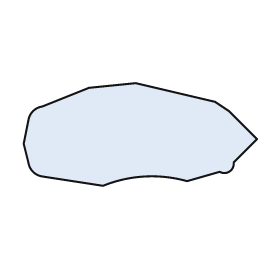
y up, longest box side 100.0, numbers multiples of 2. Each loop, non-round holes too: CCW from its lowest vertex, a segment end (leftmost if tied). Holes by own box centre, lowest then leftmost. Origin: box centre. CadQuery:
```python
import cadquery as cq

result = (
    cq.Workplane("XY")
    .moveTo(-16.0, -22.0)
    .threePointArc((2.0, -18.0), (20.0, -20.0))
    .lineTo(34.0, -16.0)
    .threePointArc((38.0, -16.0), (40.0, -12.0))
    .lineTo(50.0, -2.0)
    .lineTo(38.0, 10.0)
    .lineTo(32.0, 14.0)
    .lineTo(-2.0, 22.0)
    .lineTo(-22.0, 20.0)
    .lineTo(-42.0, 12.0)
    .threePointArc((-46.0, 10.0), (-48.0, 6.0))
    .lineTo(-50.0, -4.0)
    .lineTo(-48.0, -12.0)
    .threePointArc((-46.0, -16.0), (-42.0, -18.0))
    .close()
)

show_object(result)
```